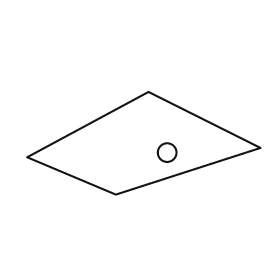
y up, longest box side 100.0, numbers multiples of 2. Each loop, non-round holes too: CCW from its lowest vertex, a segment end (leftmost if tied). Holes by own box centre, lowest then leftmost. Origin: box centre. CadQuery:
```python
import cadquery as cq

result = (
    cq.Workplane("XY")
    .moveTo(-12.0, -22.0)
    .lineTo(50.0, -2.0)
    .lineTo(2.0, 22.0)
    .lineTo(-50.0, -6.0)
    .close()
    .moveTo(10.0, -4.0)
    .circle(4.0)
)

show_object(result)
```